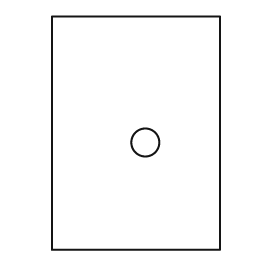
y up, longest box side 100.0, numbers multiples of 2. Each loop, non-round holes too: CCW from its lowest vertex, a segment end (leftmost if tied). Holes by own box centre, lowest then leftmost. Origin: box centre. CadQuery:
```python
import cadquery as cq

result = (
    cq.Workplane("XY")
    .moveTo(-36.0, -50.0)
    .lineTo(36.0, -50.0)
    .lineTo(36.0, 50.0)
    .lineTo(-36.0, 50.0)
    .close()
    .moveTo(4.0, -4.0)
    .circle(6.0)
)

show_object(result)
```